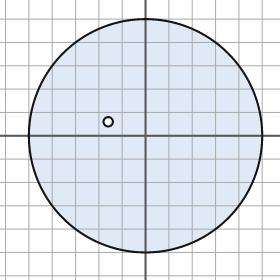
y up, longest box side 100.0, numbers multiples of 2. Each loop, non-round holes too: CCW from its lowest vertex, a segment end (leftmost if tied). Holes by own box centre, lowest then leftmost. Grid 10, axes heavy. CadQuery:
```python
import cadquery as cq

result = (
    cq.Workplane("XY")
    .moveTo(0.0, 0.0)
    .circle(50.0)
    .moveTo(-16.0, 6.0)
    .circle(2.0)
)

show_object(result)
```